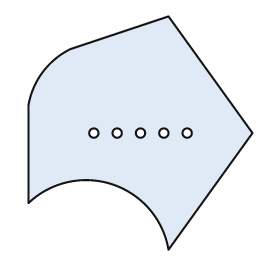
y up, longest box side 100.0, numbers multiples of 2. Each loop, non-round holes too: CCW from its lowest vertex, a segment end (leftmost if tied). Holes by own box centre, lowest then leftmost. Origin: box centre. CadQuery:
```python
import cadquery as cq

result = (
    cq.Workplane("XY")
    .moveTo(12.0, -50.0)
    .lineTo(48.0, 0.0)
    .lineTo(12.0, 50.0)
    .lineTo(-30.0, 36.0)
    .threePointArc((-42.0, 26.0), (-48.0, 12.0))
    .lineTo(-48.0, -30.0)
    .threePointArc((-12.0, -22.0), (12.0, -50.0))
    .close()
    .moveTo(-20.0, 0.0)
    .circle(2.0)
    .moveTo(-10.0, 0.0)
    .circle(2.0)
    .moveTo(0.0, 0.0)
    .circle(2.0)
    .moveTo(10.0, 0.0)
    .circle(2.0)
    .moveTo(20.0, 0.0)
    .circle(2.0)
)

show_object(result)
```